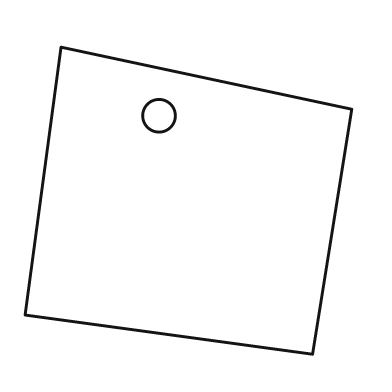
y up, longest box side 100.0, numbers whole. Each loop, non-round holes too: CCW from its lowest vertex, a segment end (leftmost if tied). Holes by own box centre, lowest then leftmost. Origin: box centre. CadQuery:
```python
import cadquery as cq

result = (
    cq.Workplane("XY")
    .moveTo(38.0, -47.0)
    .lineTo(50.0, 28.0)
    .lineTo(-39.0, 47.0)
    .lineTo(-50.0, -35.0)
    .close()
    .moveTo(-9.0, 26.0)
    .circle(5.0)
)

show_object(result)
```